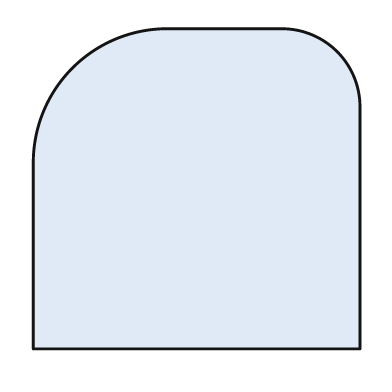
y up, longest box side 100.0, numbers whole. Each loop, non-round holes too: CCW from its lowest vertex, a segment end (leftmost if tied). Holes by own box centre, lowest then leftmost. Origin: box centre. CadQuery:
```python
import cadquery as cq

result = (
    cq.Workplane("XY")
    .moveTo(-50.0, -49.0)
    .lineTo(50.0, -49.0)
    .lineTo(50.0, 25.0)
    .threePointArc((43.0, 42.0), (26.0, 49.0))
    .lineTo(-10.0, 49.0)
    .threePointArc((-38.0, 37.0), (-50.0, 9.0))
    .close()
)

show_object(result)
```